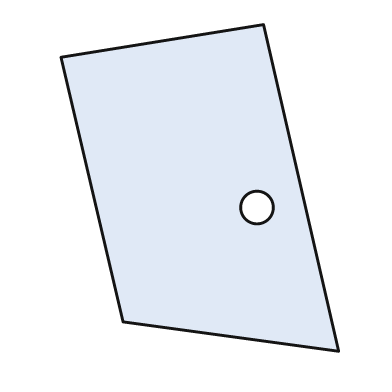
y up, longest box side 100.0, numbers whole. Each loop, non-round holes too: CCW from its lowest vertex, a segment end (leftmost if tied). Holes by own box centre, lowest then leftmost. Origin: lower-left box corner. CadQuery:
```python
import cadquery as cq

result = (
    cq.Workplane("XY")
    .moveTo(85.0, 0.0)
    .lineTo(62.0, 100.0)
    .lineTo(0.0, 90.0)
    .lineTo(19.0, 9.0)
    .close()
    .moveTo(60.0, 44.0)
    .circle(5.0)
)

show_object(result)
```